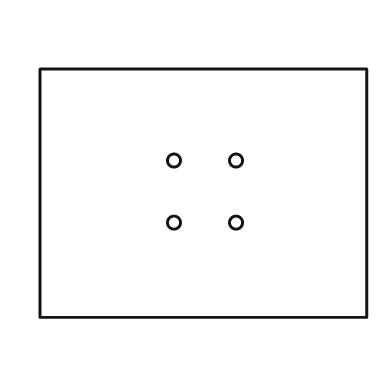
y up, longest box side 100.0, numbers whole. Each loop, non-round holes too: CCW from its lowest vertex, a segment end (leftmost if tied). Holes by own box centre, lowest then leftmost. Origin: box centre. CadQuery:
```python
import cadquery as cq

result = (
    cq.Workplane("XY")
    .moveTo(-50.0, -38.0)
    .lineTo(50.0, -38.0)
    .lineTo(50.0, 38.0)
    .lineTo(-50.0, 38.0)
    .close()
    .moveTo(-9.0, -9.0)
    .circle(2.0)
    .moveTo(10.0, -9.0)
    .circle(2.0)
    .moveTo(-9.0, 10.0)
    .circle(2.0)
    .moveTo(10.0, 10.0)
    .circle(2.0)
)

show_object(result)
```